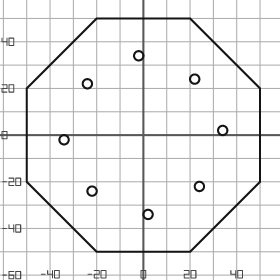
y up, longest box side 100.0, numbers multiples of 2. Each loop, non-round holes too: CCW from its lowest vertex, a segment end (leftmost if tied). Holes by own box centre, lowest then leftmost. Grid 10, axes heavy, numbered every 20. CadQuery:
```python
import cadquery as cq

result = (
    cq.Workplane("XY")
    .moveTo(-20.0, -50.0)
    .lineTo(20.0, -50.0)
    .lineTo(50.0, -20.0)
    .lineTo(50.0, 20.0)
    .lineTo(20.0, 50.0)
    .lineTo(-20.0, 50.0)
    .lineTo(-50.0, 20.0)
    .lineTo(-50.0, -20.0)
    .close()
    .moveTo(2.0, -34.0)
    .circle(2.0)
    .moveTo(-22.0, -24.0)
    .circle(2.0)
    .moveTo(24.0, -22.0)
    .circle(2.0)
    .moveTo(-34.0, -2.0)
    .circle(2.0)
    .moveTo(34.0, 2.0)
    .circle(2.0)
    .moveTo(-24.0, 22.0)
    .circle(2.0)
    .moveTo(22.0, 24.0)
    .circle(2.0)
    .moveTo(-2.0, 34.0)
    .circle(2.0)
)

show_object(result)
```